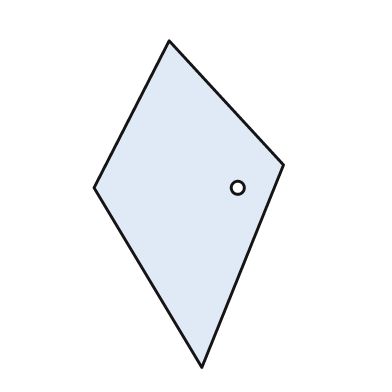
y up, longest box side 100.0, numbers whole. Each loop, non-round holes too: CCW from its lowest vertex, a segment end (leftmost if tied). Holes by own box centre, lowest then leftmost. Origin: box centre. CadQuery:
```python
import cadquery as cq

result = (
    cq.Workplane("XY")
    .moveTo(4.0, -50.0)
    .lineTo(29.0, 12.0)
    .lineTo(-6.0, 50.0)
    .lineTo(-29.0, 5.0)
    .close()
    .moveTo(15.0, 5.0)
    .circle(2.0)
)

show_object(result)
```